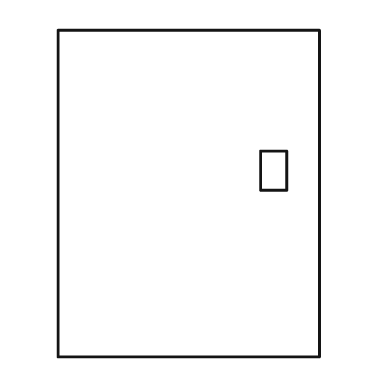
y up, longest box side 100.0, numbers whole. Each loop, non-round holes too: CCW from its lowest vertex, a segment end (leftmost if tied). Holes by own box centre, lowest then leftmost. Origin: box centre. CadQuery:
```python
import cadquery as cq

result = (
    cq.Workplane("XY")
    .moveTo(-40.0, -50.0)
    .lineTo(40.0, -50.0)
    .lineTo(40.0, 50.0)
    .lineTo(-40.0, 50.0)
    .close()
    .moveTo(22.0, 1.0)
    .lineTo(30.0, 1.0)
    .lineTo(30.0, 13.0)
    .lineTo(22.0, 13.0)
    .close()
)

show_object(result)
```